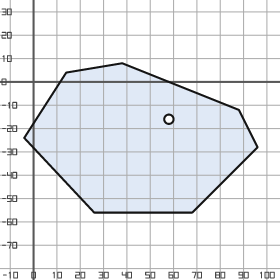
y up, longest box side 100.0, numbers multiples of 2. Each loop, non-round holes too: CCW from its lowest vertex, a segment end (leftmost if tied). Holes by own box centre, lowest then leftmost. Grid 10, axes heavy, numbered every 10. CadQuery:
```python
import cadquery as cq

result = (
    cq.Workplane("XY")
    .moveTo(26.0, -56.0)
    .lineTo(68.0, -56.0)
    .lineTo(96.0, -28.0)
    .lineTo(88.0, -12.0)
    .lineTo(38.0, 8.0)
    .lineTo(14.0, 4.0)
    .lineTo(-4.0, -24.0)
    .close()
    .moveTo(58.0, -16.0)
    .circle(2.0)
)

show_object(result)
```